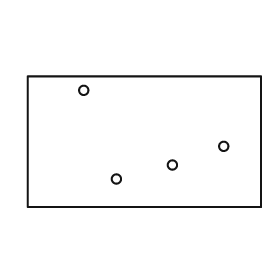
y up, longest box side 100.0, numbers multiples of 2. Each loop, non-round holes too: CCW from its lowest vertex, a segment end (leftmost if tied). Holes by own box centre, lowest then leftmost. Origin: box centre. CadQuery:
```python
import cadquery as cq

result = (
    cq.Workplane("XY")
    .moveTo(-50.0, -28.0)
    .lineTo(50.0, -28.0)
    .lineTo(50.0, 28.0)
    .lineTo(-50.0, 28.0)
    .close()
    .moveTo(-12.0, -16.0)
    .circle(2.0)
    .moveTo(12.0, -10.0)
    .circle(2.0)
    .moveTo(34.0, -2.0)
    .circle(2.0)
    .moveTo(-26.0, 22.0)
    .circle(2.0)
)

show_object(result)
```